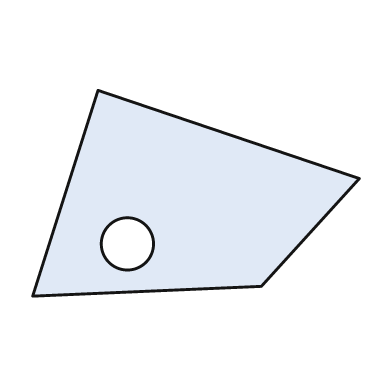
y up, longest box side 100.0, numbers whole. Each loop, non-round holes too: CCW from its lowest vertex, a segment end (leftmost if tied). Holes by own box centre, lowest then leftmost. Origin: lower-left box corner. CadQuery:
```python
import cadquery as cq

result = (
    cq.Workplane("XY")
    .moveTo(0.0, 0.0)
    .lineTo(70.0, 3.0)
    .lineTo(100.0, 36.0)
    .lineTo(20.0, 63.0)
    .close()
    .moveTo(29.0, 16.0)
    .circle(8.0)
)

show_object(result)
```